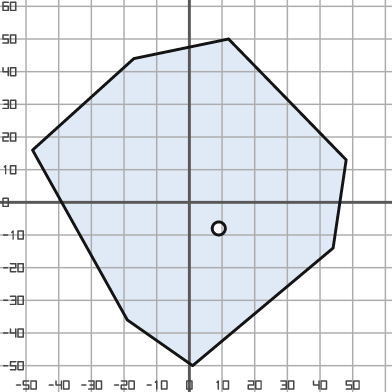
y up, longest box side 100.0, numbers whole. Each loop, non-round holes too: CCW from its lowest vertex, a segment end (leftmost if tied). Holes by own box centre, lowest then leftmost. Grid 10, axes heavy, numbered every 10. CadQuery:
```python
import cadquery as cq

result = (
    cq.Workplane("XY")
    .moveTo(1.0, -50.0)
    .lineTo(44.0, -14.0)
    .lineTo(48.0, 13.0)
    .lineTo(12.0, 50.0)
    .lineTo(-17.0, 44.0)
    .lineTo(-48.0, 16.0)
    .lineTo(-19.0, -36.0)
    .close()
    .moveTo(9.0, -8.0)
    .circle(2.0)
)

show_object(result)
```